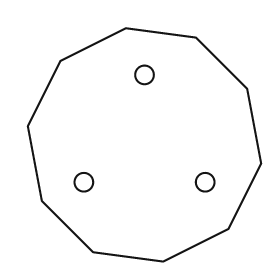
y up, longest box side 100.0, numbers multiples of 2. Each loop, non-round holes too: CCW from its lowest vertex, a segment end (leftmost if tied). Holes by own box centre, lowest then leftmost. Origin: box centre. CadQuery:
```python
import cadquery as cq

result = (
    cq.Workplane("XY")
    .moveTo(8.0, -50.0)
    .lineTo(36.0, -36.0)
    .lineTo(50.0, -8.0)
    .lineTo(44.0, 24.0)
    .lineTo(22.0, 46.0)
    .lineTo(-8.0, 50.0)
    .lineTo(-36.0, 36.0)
    .lineTo(-50.0, 8.0)
    .lineTo(-44.0, -24.0)
    .lineTo(-22.0, -46.0)
    .close()
    .moveTo(-26.0, -16.0)
    .circle(4.0)
    .moveTo(26.0, -16.0)
    .circle(4.0)
    .moveTo(0.0, 30.0)
    .circle(4.0)
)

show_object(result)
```